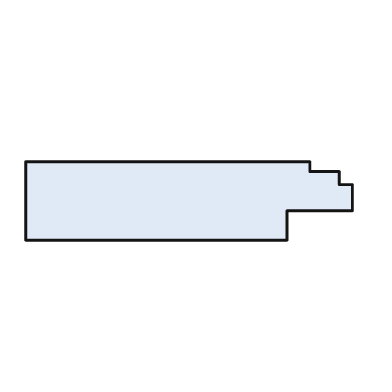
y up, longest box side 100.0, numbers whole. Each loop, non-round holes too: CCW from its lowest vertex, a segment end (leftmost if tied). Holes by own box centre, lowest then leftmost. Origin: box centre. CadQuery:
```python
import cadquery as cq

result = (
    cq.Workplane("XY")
    .moveTo(-50.0, -12.0)
    .lineTo(30.0, -12.0)
    .lineTo(30.0, -3.0)
    .lineTo(50.0, -3.0)
    .lineTo(50.0, 5.0)
    .lineTo(46.0, 5.0)
    .lineTo(46.0, 9.0)
    .lineTo(37.0, 9.0)
    .lineTo(37.0, 12.0)
    .lineTo(-50.0, 12.0)
    .close()
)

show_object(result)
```